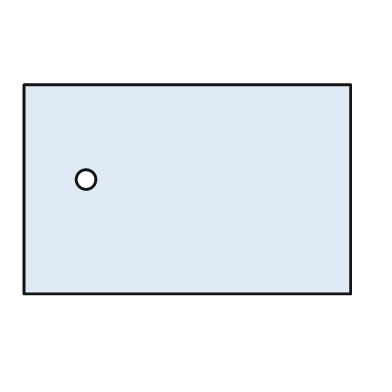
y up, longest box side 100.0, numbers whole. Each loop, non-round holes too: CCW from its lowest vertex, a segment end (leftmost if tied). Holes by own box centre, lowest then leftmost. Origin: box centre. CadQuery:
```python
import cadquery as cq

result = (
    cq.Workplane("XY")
    .moveTo(-50.0, -32.0)
    .lineTo(50.0, -32.0)
    .lineTo(50.0, 32.0)
    .lineTo(-50.0, 32.0)
    .close()
    .moveTo(-31.0, 3.0)
    .circle(3.0)
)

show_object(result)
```